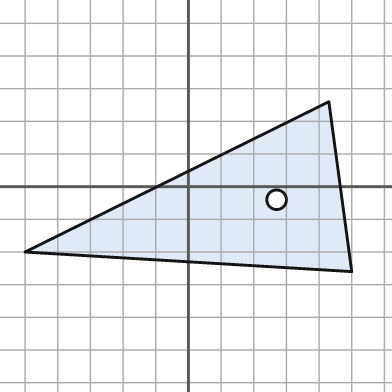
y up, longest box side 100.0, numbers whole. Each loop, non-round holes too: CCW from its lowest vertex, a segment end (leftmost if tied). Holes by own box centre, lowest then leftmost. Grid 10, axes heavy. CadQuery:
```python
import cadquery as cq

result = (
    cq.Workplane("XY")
    .moveTo(50.0, -26.0)
    .lineTo(43.0, 26.0)
    .lineTo(-50.0, -20.0)
    .close()
    .moveTo(27.0, -4.0)
    .circle(3.0)
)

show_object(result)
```